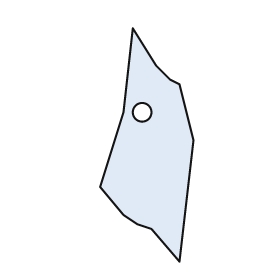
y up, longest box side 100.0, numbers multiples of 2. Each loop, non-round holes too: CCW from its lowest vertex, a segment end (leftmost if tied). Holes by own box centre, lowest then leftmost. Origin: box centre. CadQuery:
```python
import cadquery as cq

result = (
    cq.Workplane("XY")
    .moveTo(14.0, -50.0)
    .lineTo(20.0, 2.0)
    .lineTo(14.0, 26.0)
    .lineTo(10.0, 28.0)
    .lineTo(4.0, 34.0)
    .lineTo(-6.0, 50.0)
    .lineTo(-10.0, 14.0)
    .lineTo(-20.0, -18.0)
    .lineTo(-10.0, -30.0)
    .lineTo(-4.0, -34.0)
    .lineTo(2.0, -36.0)
    .close()
    .moveTo(-2.0, 14.0)
    .circle(4.0)
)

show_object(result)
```